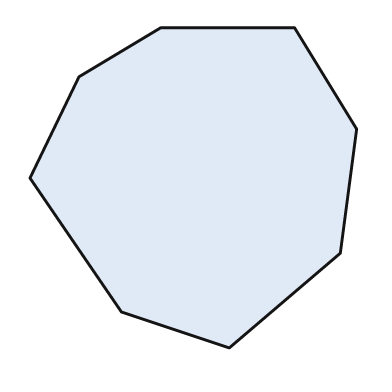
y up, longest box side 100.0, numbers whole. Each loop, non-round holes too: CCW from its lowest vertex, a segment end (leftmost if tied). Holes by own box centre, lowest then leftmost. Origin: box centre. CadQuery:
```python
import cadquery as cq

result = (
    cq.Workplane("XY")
    .moveTo(11.0, -49.0)
    .lineTo(45.0, -20.0)
    .lineTo(50.0, 18.0)
    .lineTo(31.0, 49.0)
    .lineTo(-10.0, 49.0)
    .lineTo(-35.0, 34.0)
    .lineTo(-50.0, 3.0)
    .lineTo(-22.0, -38.0)
    .close()
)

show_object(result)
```